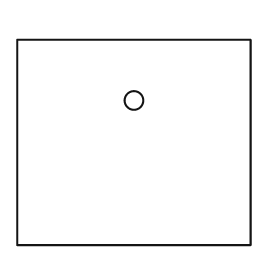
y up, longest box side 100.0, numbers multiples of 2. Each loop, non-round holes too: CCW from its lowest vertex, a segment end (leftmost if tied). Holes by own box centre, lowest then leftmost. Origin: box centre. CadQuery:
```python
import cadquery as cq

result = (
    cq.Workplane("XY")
    .moveTo(-50.0, -44.0)
    .lineTo(50.0, -44.0)
    .lineTo(50.0, 44.0)
    .lineTo(-50.0, 44.0)
    .close()
    .moveTo(0.0, 18.0)
    .circle(4.0)
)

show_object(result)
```